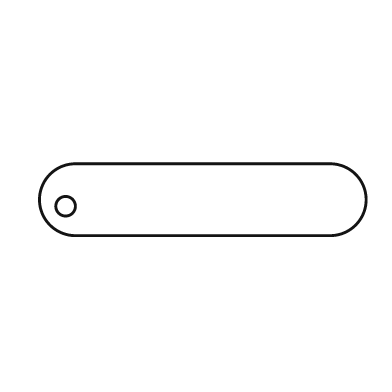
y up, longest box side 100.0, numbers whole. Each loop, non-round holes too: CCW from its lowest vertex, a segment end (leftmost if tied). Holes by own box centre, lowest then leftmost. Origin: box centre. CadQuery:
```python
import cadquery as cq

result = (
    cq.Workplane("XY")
    .moveTo(-39.0, -11.0)
    .lineTo(39.0, -11.0)
    .threePointArc((50.0, 0.0), (39.0, 11.0))
    .lineTo(-39.0, 11.0)
    .threePointArc((-50.0, 0.0), (-39.0, -11.0))
    .close()
    .moveTo(-42.0, -2.0)
    .circle(3.0)
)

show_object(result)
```